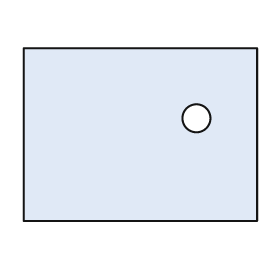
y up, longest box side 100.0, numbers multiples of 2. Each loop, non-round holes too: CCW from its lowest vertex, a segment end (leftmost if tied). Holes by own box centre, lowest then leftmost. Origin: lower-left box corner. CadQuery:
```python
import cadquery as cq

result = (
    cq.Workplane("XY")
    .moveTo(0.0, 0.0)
    .lineTo(100.0, 0.0)
    .lineTo(100.0, 74.0)
    .lineTo(0.0, 74.0)
    .close()
    .moveTo(74.0, 44.0)
    .circle(6.0)
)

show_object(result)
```